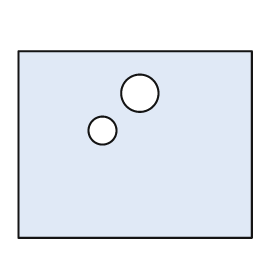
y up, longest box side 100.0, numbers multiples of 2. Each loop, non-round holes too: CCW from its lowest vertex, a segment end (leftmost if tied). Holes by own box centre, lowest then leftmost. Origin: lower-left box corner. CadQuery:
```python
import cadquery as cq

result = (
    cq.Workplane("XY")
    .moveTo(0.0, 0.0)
    .lineTo(100.0, 0.0)
    .lineTo(100.0, 80.0)
    .lineTo(0.0, 80.0)
    .close()
    .moveTo(36.0, 46.0)
    .circle(6.0)
    .moveTo(52.0, 62.0)
    .circle(8.0)
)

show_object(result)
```